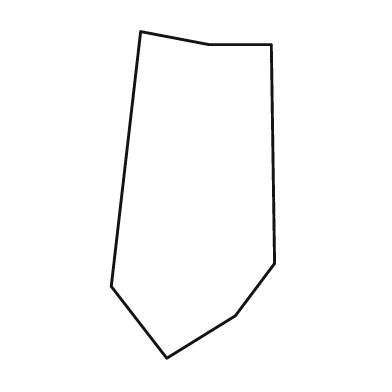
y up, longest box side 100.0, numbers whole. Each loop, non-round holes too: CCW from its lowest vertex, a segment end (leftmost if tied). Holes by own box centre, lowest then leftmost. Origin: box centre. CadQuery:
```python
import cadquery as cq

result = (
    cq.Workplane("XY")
    .moveTo(-8.0, -50.0)
    .lineTo(13.0, -37.0)
    .lineTo(25.0, -21.0)
    .lineTo(24.0, 46.0)
    .lineTo(5.0, 46.0)
    .lineTo(-16.0, 50.0)
    .lineTo(-25.0, -28.0)
    .close()
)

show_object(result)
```